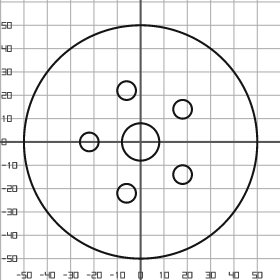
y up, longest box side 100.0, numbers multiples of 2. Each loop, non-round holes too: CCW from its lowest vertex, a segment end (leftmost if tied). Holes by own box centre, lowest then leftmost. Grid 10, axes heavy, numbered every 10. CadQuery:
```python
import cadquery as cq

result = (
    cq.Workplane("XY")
    .moveTo(0.0, 0.0)
    .circle(50.0)
    .moveTo(-6.0, -22.0)
    .circle(4.0)
    .moveTo(18.0, -14.0)
    .circle(4.0)
    .moveTo(-22.0, 0.0)
    .circle(4.0)
    .moveTo(0.0, 0.0)
    .circle(8.0)
    .moveTo(18.0, 14.0)
    .circle(4.0)
    .moveTo(-6.0, 22.0)
    .circle(4.0)
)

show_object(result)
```